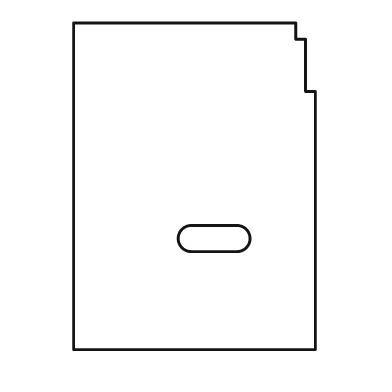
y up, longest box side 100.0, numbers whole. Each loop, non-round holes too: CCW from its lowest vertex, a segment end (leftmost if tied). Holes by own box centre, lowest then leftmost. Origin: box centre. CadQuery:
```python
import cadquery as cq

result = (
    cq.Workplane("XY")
    .moveTo(-37.0, -50.0)
    .lineTo(37.0, -50.0)
    .lineTo(37.0, 29.0)
    .lineTo(34.0, 29.0)
    .lineTo(34.0, 45.0)
    .lineTo(31.0, 45.0)
    .lineTo(31.0, 50.0)
    .lineTo(-37.0, 50.0)
    .close()
    .moveTo(-1.0, -20.0)
    .lineTo(13.0, -20.0)
    .threePointArc((17.0, -16.0), (13.0, -12.0))
    .lineTo(-1.0, -12.0)
    .threePointArc((-5.0, -16.0), (-1.0, -20.0))
    .close()
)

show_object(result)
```